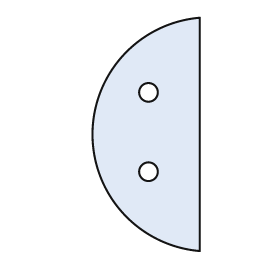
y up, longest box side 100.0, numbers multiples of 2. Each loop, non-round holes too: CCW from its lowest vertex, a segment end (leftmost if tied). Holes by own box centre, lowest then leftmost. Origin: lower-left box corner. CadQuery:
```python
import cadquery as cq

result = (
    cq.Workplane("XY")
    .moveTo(46.0, 0.0)
    .lineTo(46.0, 100.0)
    .threePointArc((0.0, 50.0), (46.0, 0.0))
    .close()
    .moveTo(24.0, 34.0)
    .circle(4.0)
    .moveTo(24.0, 68.0)
    .circle(4.0)
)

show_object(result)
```